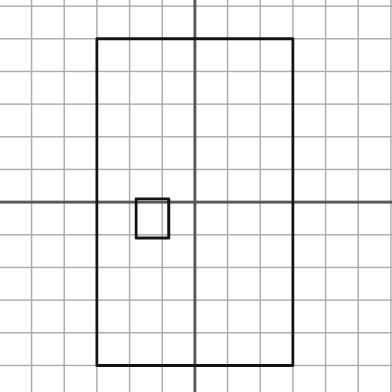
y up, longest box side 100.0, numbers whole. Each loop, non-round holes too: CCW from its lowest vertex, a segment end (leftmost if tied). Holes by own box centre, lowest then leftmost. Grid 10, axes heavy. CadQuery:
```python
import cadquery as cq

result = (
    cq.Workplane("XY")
    .moveTo(-30.0, -50.0)
    .lineTo(30.0, -50.0)
    .lineTo(30.0, 50.0)
    .lineTo(-30.0, 50.0)
    .close()
    .moveTo(-18.0, -11.0)
    .lineTo(-8.0, -11.0)
    .lineTo(-8.0, 1.0)
    .lineTo(-18.0, 1.0)
    .close()
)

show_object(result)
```